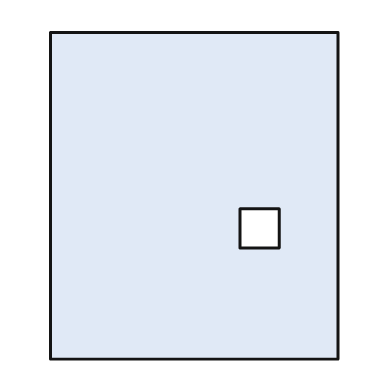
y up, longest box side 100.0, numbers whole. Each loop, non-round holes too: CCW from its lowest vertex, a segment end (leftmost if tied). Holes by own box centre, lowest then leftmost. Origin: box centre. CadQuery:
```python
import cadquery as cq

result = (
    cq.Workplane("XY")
    .moveTo(-44.0, -50.0)
    .lineTo(44.0, -50.0)
    .lineTo(44.0, 50.0)
    .lineTo(-44.0, 50.0)
    .close()
    .moveTo(14.0, -16.0)
    .lineTo(26.0, -16.0)
    .lineTo(26.0, -4.0)
    .lineTo(14.0, -4.0)
    .close()
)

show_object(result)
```